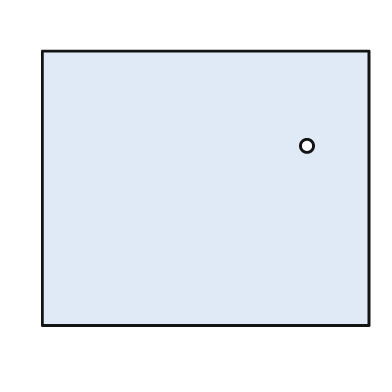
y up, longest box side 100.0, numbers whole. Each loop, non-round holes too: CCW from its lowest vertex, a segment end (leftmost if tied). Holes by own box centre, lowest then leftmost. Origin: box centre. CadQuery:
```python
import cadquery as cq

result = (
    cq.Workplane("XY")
    .moveTo(-50.0, -42.0)
    .lineTo(50.0, -42.0)
    .lineTo(50.0, 42.0)
    .lineTo(-50.0, 42.0)
    .close()
    .moveTo(31.0, 13.0)
    .circle(2.0)
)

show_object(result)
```